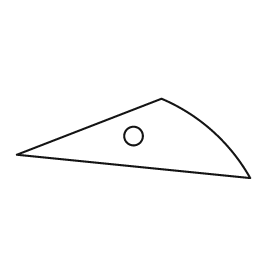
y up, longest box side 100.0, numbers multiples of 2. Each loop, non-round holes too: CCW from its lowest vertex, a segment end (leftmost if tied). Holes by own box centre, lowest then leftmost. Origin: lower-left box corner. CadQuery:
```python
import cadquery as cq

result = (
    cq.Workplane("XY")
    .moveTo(100.0, 0.0)
    .threePointArc((84.0, 20.0), (62.0, 34.0))
    .lineTo(0.0, 10.0)
    .close()
    .moveTo(50.0, 18.0)
    .circle(4.0)
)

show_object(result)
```